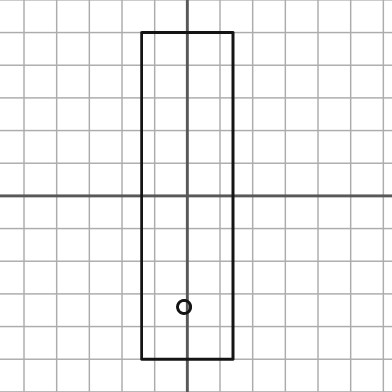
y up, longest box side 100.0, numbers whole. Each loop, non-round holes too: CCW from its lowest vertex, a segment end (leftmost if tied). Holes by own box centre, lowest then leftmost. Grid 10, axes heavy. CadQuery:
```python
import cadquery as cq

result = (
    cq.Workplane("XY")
    .moveTo(-14.0, -50.0)
    .lineTo(14.0, -50.0)
    .lineTo(14.0, 50.0)
    .lineTo(-14.0, 50.0)
    .close()
    .moveTo(-1.0, -34.0)
    .circle(2.0)
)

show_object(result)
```